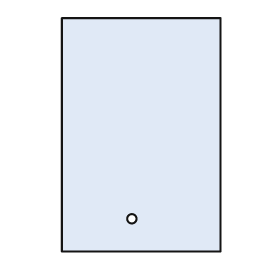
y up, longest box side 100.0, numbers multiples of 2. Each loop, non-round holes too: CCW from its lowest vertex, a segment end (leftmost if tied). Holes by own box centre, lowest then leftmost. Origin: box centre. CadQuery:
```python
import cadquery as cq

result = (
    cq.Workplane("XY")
    .moveTo(-34.0, -50.0)
    .lineTo(34.0, -50.0)
    .lineTo(34.0, 50.0)
    .lineTo(-34.0, 50.0)
    .close()
    .moveTo(-4.0, -36.0)
    .circle(2.0)
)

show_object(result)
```